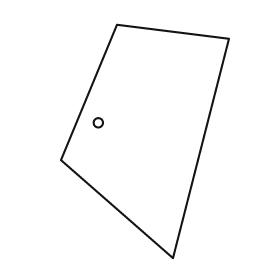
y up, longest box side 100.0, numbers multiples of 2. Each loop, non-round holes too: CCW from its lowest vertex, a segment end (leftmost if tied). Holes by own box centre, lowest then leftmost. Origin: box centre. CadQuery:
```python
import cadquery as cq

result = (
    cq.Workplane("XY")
    .moveTo(12.0, -50.0)
    .lineTo(36.0, 44.0)
    .lineTo(-12.0, 50.0)
    .lineTo(-36.0, -8.0)
    .close()
    .moveTo(-20.0, 8.0)
    .circle(2.0)
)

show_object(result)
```